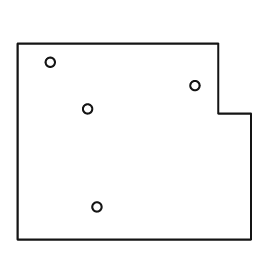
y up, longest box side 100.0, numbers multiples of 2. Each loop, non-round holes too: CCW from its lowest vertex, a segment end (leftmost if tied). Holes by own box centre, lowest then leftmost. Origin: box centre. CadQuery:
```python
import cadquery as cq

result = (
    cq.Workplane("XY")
    .moveTo(-50.0, -42.0)
    .lineTo(50.0, -42.0)
    .lineTo(50.0, 12.0)
    .lineTo(36.0, 12.0)
    .lineTo(36.0, 42.0)
    .lineTo(-50.0, 42.0)
    .close()
    .moveTo(-16.0, -28.0)
    .circle(2.0)
    .moveTo(-20.0, 14.0)
    .circle(2.0)
    .moveTo(26.0, 24.0)
    .circle(2.0)
    .moveTo(-36.0, 34.0)
    .circle(2.0)
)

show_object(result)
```